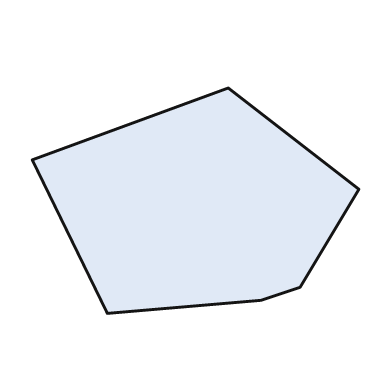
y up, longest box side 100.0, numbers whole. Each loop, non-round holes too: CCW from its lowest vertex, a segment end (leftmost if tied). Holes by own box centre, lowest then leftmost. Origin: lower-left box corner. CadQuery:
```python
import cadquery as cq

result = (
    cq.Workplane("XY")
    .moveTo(23.0, 0.0)
    .lineTo(70.0, 4.0)
    .lineTo(82.0, 8.0)
    .lineTo(100.0, 38.0)
    .lineTo(60.0, 69.0)
    .lineTo(0.0, 47.0)
    .close()
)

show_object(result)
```